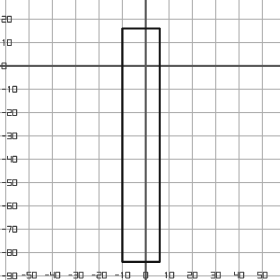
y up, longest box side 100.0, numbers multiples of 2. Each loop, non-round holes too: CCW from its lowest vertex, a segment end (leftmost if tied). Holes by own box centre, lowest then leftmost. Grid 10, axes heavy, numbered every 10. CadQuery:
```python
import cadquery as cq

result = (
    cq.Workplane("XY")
    .moveTo(-10.0, -84.0)
    .lineTo(6.0, -84.0)
    .lineTo(6.0, 16.0)
    .lineTo(-10.0, 16.0)
    .close()
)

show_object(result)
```